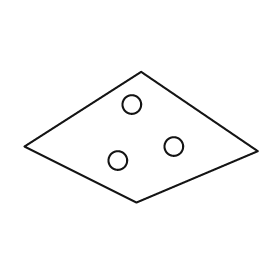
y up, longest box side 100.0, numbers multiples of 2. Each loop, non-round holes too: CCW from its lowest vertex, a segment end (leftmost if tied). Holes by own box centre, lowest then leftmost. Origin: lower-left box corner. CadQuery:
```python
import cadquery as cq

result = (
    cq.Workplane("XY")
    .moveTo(48.0, 0.0)
    .lineTo(100.0, 22.0)
    .lineTo(50.0, 56.0)
    .lineTo(0.0, 24.0)
    .close()
    .moveTo(40.0, 18.0)
    .circle(4.0)
    .moveTo(64.0, 24.0)
    .circle(4.0)
    .moveTo(46.0, 42.0)
    .circle(4.0)
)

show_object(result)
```